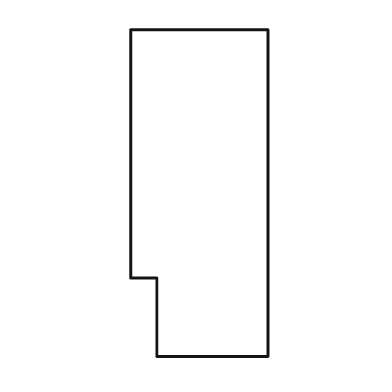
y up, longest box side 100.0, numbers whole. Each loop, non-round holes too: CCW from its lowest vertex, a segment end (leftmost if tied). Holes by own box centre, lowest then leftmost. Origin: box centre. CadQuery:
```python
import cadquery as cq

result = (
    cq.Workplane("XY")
    .moveTo(-13.0, -50.0)
    .lineTo(21.0, -50.0)
    .lineTo(21.0, 50.0)
    .lineTo(-21.0, 50.0)
    .lineTo(-21.0, -26.0)
    .lineTo(-13.0, -26.0)
    .close()
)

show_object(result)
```